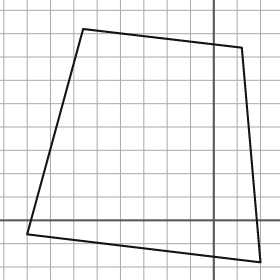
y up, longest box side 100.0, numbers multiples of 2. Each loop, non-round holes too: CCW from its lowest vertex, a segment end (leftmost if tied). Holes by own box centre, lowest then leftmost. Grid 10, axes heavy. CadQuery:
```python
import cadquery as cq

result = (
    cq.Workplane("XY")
    .moveTo(20.0, -18.0)
    .lineTo(12.0, 74.0)
    .lineTo(-56.0, 82.0)
    .lineTo(-80.0, -6.0)
    .close()
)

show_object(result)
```